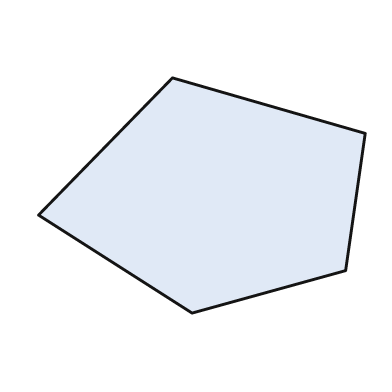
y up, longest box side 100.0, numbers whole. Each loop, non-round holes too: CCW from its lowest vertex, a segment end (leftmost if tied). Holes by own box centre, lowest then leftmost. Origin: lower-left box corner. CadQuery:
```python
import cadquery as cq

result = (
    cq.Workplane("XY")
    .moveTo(47.0, 0.0)
    .lineTo(94.0, 13.0)
    .lineTo(100.0, 55.0)
    .lineTo(41.0, 72.0)
    .lineTo(0.0, 30.0)
    .close()
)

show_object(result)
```